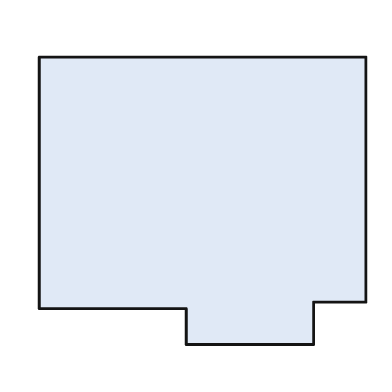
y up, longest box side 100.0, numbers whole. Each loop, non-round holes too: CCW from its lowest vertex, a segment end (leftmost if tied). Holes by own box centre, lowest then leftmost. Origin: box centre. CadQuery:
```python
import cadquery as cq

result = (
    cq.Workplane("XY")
    .moveTo(-5.0, -44.0)
    .lineTo(34.0, -44.0)
    .lineTo(34.0, -31.0)
    .lineTo(50.0, -31.0)
    .lineTo(50.0, 44.0)
    .lineTo(-50.0, 44.0)
    .lineTo(-50.0, -33.0)
    .lineTo(-5.0, -33.0)
    .close()
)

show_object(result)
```